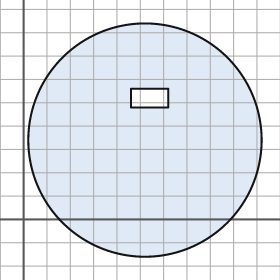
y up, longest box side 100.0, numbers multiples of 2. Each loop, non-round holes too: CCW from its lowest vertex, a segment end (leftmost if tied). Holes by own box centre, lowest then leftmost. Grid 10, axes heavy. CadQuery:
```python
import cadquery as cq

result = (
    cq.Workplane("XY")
    .moveTo(52.0, 34.0)
    .circle(50.0)
    .moveTo(46.0, 48.0)
    .lineTo(62.0, 48.0)
    .lineTo(62.0, 56.0)
    .lineTo(46.0, 56.0)
    .close()
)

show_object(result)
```